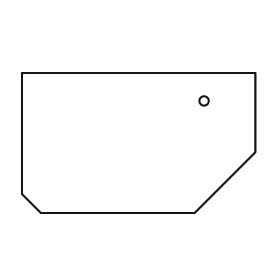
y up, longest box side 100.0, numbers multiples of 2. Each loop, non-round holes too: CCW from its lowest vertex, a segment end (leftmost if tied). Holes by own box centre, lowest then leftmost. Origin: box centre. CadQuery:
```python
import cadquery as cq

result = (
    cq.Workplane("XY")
    .moveTo(-42.0, -30.0)
    .lineTo(24.0, -30.0)
    .lineTo(50.0, -4.0)
    .lineTo(50.0, 30.0)
    .lineTo(-50.0, 30.0)
    .lineTo(-50.0, -22.0)
    .close()
    .moveTo(28.0, 18.0)
    .circle(2.0)
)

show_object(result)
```